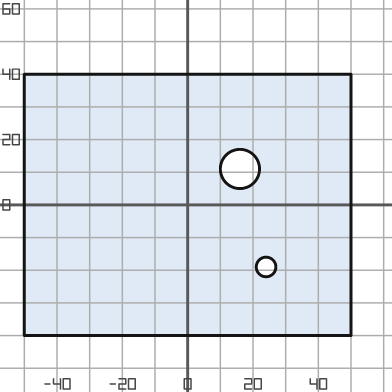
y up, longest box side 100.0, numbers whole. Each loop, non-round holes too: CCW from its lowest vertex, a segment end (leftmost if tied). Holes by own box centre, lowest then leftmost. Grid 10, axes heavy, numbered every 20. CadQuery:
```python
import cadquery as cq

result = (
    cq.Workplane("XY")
    .moveTo(-50.0, -40.0)
    .lineTo(50.0, -40.0)
    .lineTo(50.0, 40.0)
    .lineTo(-50.0, 40.0)
    .close()
    .moveTo(24.0, -19.0)
    .circle(3.0)
    .moveTo(16.0, 11.0)
    .circle(6.0)
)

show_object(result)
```